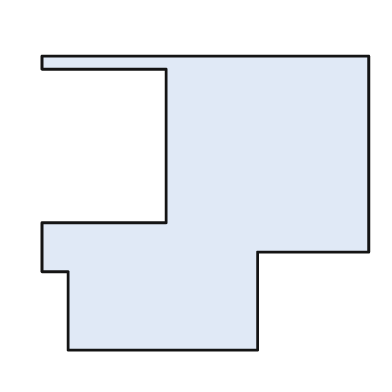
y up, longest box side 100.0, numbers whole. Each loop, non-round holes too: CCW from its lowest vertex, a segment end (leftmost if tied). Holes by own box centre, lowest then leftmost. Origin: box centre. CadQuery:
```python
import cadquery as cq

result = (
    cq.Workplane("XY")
    .moveTo(-42.0, -45.0)
    .lineTo(16.0, -45.0)
    .lineTo(16.0, -15.0)
    .lineTo(50.0, -15.0)
    .lineTo(50.0, 45.0)
    .lineTo(-50.0, 45.0)
    .lineTo(-50.0, 41.0)
    .lineTo(-12.0, 41.0)
    .lineTo(-12.0, -6.0)
    .lineTo(-50.0, -6.0)
    .lineTo(-50.0, -21.0)
    .lineTo(-42.0, -21.0)
    .close()
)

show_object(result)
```